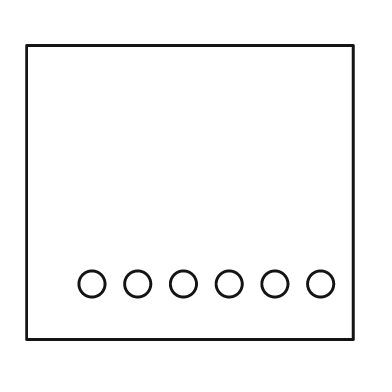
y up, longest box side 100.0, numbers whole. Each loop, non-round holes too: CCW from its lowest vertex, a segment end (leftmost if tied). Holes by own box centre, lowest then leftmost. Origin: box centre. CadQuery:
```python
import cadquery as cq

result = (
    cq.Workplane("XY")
    .moveTo(-50.0, -45.0)
    .lineTo(50.0, -45.0)
    .lineTo(50.0, 45.0)
    .lineTo(-50.0, 45.0)
    .close()
    .moveTo(-30.0, -28.0)
    .circle(4.0)
    .moveTo(-16.0, -28.0)
    .circle(4.0)
    .moveTo(-2.0, -28.0)
    .circle(4.0)
    .moveTo(12.0, -28.0)
    .circle(4.0)
    .moveTo(26.0, -28.0)
    .circle(4.0)
    .moveTo(40.0, -28.0)
    .circle(4.0)
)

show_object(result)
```